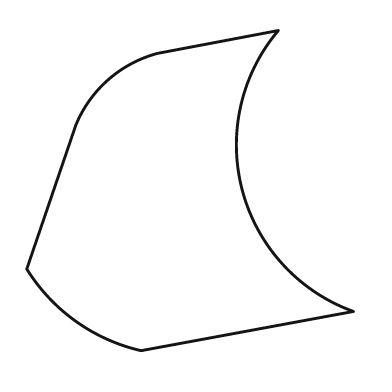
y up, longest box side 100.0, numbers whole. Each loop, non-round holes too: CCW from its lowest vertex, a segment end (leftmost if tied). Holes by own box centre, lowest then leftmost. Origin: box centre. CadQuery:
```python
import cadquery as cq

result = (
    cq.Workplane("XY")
    .moveTo(-15.0, -49.0)
    .lineTo(50.0, -37.0)
    .threePointArc((16.0, 0.0), (27.0, 49.0))
    .lineTo(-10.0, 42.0)
    .threePointArc((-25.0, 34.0), (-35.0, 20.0))
    .lineTo(-50.0, -24.0)
    .threePointArc((-35.0, -40.0), (-15.0, -49.0))
    .close()
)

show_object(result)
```